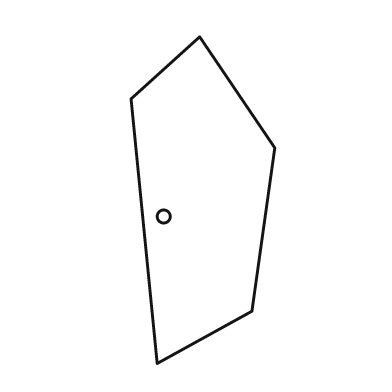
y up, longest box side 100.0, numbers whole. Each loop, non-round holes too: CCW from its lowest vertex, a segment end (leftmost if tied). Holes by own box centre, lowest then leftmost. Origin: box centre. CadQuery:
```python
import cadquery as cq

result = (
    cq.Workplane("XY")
    .moveTo(-14.0, -50.0)
    .lineTo(15.0, -34.0)
    .lineTo(22.0, 16.0)
    .lineTo(-1.0, 50.0)
    .lineTo(-22.0, 31.0)
    .close()
    .moveTo(-12.0, -5.0)
    .circle(2.0)
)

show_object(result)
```